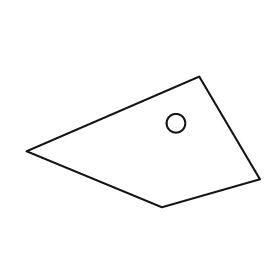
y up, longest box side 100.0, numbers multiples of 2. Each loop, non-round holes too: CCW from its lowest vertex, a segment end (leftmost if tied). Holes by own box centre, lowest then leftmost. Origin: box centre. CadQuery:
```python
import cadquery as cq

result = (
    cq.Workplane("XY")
    .moveTo(8.0, -28.0)
    .lineTo(50.0, -16.0)
    .lineTo(24.0, 28.0)
    .lineTo(-50.0, -4.0)
    .close()
    .moveTo(14.0, 8.0)
    .circle(4.0)
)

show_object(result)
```